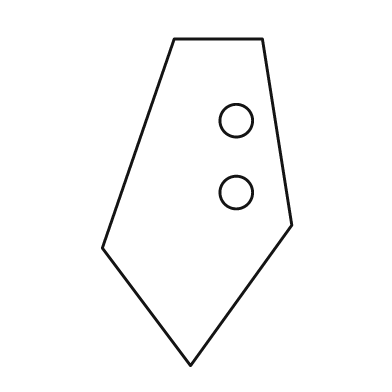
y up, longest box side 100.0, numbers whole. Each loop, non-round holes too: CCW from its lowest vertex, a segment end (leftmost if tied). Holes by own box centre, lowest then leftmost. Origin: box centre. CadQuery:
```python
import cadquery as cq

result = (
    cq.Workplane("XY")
    .moveTo(-2.0, -50.0)
    .lineTo(29.0, -7.0)
    .lineTo(20.0, 50.0)
    .lineTo(-7.0, 50.0)
    .lineTo(-29.0, -14.0)
    .close()
    .moveTo(12.0, 3.0)
    .circle(5.0)
    .moveTo(12.0, 25.0)
    .circle(5.0)
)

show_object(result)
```